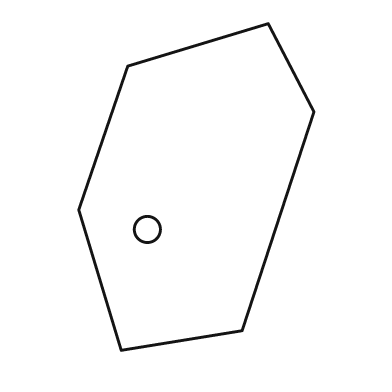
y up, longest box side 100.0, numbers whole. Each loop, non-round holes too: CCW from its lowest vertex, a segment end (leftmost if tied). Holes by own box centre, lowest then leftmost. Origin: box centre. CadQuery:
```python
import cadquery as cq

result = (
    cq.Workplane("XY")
    .moveTo(-23.0, -50.0)
    .lineTo(14.0, -44.0)
    .lineTo(36.0, 23.0)
    .lineTo(22.0, 50.0)
    .lineTo(-21.0, 37.0)
    .lineTo(-36.0, -7.0)
    .close()
    .moveTo(-15.0, -13.0)
    .circle(4.0)
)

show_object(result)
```